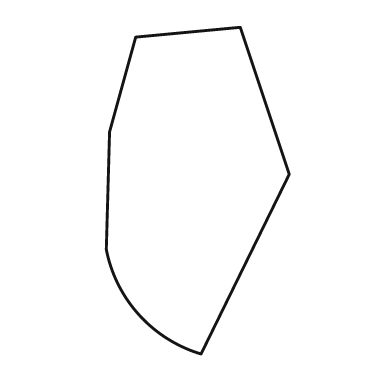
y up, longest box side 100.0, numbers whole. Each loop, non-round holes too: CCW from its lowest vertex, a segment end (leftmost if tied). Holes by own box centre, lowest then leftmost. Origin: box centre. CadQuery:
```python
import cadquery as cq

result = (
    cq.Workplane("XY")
    .moveTo(1.0, -50.0)
    .lineTo(28.0, 5.0)
    .lineTo(13.0, 50.0)
    .lineTo(-19.0, 47.0)
    .lineTo(-27.0, 18.0)
    .lineTo(-28.0, -18.0)
    .threePointArc((-18.0, -38.0), (1.0, -50.0))
    .close()
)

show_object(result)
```